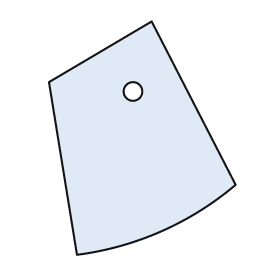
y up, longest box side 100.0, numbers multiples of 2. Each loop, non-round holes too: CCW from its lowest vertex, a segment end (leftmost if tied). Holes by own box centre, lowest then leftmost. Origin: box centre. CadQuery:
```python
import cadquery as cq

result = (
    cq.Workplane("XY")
    .moveTo(-28.0, -50.0)
    .threePointArc((8.0, -40.0), (40.0, -20.0))
    .lineTo(4.0, 50.0)
    .lineTo(-40.0, 24.0)
    .close()
    .moveTo(-4.0, 20.0)
    .circle(4.0)
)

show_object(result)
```